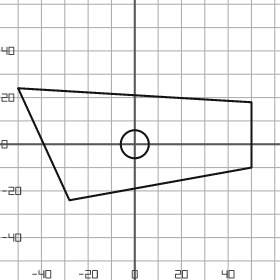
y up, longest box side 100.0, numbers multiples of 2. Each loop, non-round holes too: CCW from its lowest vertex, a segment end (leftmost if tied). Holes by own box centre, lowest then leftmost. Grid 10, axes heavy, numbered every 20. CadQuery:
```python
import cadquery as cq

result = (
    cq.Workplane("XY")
    .moveTo(-28.0, -24.0)
    .lineTo(50.0, -10.0)
    .lineTo(50.0, 18.0)
    .lineTo(-50.0, 24.0)
    .close()
    .moveTo(0.0, 0.0)
    .circle(6.0)
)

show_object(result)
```